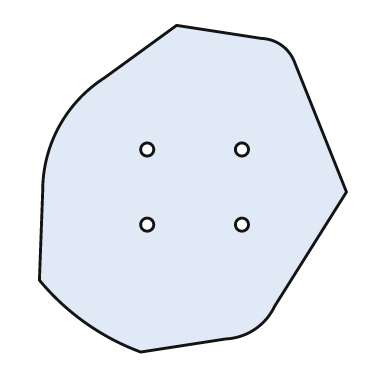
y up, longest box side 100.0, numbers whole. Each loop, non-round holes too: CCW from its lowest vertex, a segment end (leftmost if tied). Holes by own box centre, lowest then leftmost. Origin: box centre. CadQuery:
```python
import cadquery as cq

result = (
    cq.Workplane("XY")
    .moveTo(-16.0, -50.0)
    .lineTo(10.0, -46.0)
    .threePointArc((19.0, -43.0), (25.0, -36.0))
    .lineTo(47.0, -1.0)
    .lineTo(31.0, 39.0)
    .threePointArc((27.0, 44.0), (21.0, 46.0))
    .lineTo(-5.0, 50.0)
    .lineTo(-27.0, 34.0)
    .threePointArc((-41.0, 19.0), (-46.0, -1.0))
    .lineTo(-47.0, -28.0)
    .threePointArc((-33.0, -41.0), (-16.0, -50.0))
    .close()
    .moveTo(-14.0, -11.0)
    .circle(2.0)
    .moveTo(15.0, -11.0)
    .circle(2.0)
    .moveTo(-14.0, 12.0)
    .circle(2.0)
    .moveTo(15.0, 12.0)
    .circle(2.0)
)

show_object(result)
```